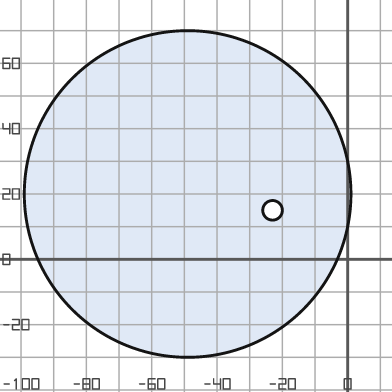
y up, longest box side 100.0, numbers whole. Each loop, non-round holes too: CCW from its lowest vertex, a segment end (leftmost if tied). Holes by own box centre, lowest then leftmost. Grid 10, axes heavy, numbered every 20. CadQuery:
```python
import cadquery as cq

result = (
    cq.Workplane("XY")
    .moveTo(-49.0, 20.0)
    .circle(50.0)
    .moveTo(-23.0, 15.0)
    .circle(3.0)
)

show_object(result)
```